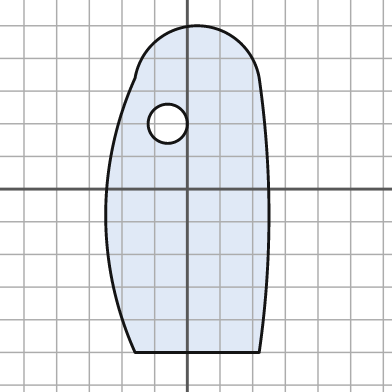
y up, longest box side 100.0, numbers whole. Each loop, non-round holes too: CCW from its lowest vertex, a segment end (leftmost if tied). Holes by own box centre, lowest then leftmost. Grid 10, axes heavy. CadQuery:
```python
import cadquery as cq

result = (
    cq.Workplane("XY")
    .moveTo(-16.0, -50.0)
    .lineTo(22.0, -50.0)
    .threePointArc((25.0, -8.0), (22.0, 34.0))
    .threePointArc((3.0, 50.0), (-16.0, 34.0))
    .threePointArc((-25.0, -8.0), (-16.0, -50.0))
    .close()
    .moveTo(-6.0, 20.0)
    .circle(6.0)
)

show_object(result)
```